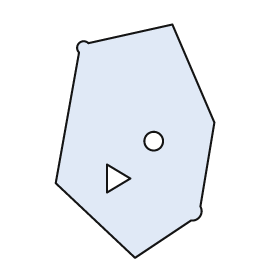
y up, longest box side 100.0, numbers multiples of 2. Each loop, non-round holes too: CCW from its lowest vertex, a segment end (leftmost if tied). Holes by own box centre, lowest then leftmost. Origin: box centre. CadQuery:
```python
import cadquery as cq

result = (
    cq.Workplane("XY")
    .moveTo(0.0, -50.0)
    .lineTo(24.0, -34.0)
    .threePointArc((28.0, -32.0), (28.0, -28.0))
    .lineTo(34.0, 8.0)
    .lineTo(16.0, 50.0)
    .lineTo(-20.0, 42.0)
    .threePointArc((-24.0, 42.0), (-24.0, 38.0))
    .lineTo(-34.0, -18.0)
    .close()
    .moveTo(-12.0, -22.0)
    .lineTo(-2.0, -16.0)
    .lineTo(-12.0, -10.0)
    .close()
    .moveTo(8.0, 0.0)
    .circle(4.0)
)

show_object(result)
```